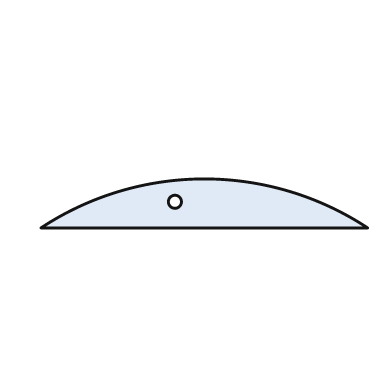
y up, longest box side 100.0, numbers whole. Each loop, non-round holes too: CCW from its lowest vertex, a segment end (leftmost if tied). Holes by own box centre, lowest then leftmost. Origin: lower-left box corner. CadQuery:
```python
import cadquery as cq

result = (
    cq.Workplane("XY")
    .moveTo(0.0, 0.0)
    .lineTo(100.0, 0.0)
    .threePointArc((50.0, 15.0), (0.0, 0.0))
    .close()
    .moveTo(41.0, 8.0)
    .circle(2.0)
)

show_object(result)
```